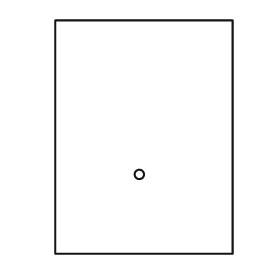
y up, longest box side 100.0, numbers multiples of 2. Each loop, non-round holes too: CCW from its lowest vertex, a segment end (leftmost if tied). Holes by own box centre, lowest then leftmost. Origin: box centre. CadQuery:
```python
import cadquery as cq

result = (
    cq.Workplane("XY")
    .moveTo(-38.0, -50.0)
    .lineTo(38.0, -50.0)
    .lineTo(38.0, 50.0)
    .lineTo(-38.0, 50.0)
    .close()
    .moveTo(-2.0, -16.0)
    .circle(2.0)
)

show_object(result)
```